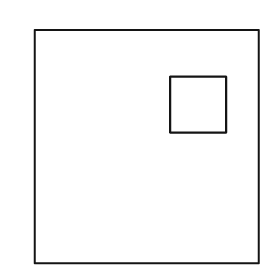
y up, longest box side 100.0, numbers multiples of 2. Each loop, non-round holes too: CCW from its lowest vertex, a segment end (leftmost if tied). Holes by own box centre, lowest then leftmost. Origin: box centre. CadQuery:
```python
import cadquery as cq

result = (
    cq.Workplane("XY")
    .moveTo(-48.0, -50.0)
    .lineTo(48.0, -50.0)
    .lineTo(48.0, 50.0)
    .lineTo(-48.0, 50.0)
    .close()
    .moveTo(10.0, 6.0)
    .lineTo(34.0, 6.0)
    .lineTo(34.0, 30.0)
    .lineTo(10.0, 30.0)
    .close()
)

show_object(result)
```